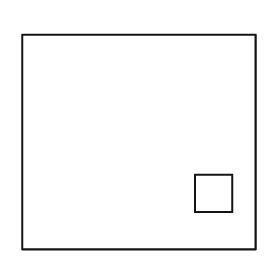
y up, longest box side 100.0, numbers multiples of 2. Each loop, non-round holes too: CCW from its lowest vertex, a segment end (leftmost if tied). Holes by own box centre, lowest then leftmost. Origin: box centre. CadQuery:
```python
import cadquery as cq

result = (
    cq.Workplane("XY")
    .moveTo(-50.0, -46.0)
    .lineTo(50.0, -46.0)
    .lineTo(50.0, 46.0)
    .lineTo(-50.0, 46.0)
    .close()
    .moveTo(24.0, -30.0)
    .lineTo(40.0, -30.0)
    .lineTo(40.0, -14.0)
    .lineTo(24.0, -14.0)
    .close()
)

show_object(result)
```